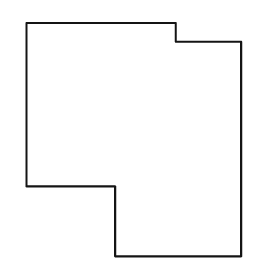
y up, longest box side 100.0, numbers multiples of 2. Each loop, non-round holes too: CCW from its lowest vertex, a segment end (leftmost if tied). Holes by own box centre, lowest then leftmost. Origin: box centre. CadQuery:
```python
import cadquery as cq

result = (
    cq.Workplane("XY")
    .moveTo(-8.0, -50.0)
    .lineTo(46.0, -50.0)
    .lineTo(46.0, 42.0)
    .lineTo(18.0, 42.0)
    .lineTo(18.0, 50.0)
    .lineTo(-46.0, 50.0)
    .lineTo(-46.0, -20.0)
    .lineTo(-8.0, -20.0)
    .close()
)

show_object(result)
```